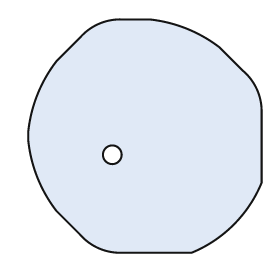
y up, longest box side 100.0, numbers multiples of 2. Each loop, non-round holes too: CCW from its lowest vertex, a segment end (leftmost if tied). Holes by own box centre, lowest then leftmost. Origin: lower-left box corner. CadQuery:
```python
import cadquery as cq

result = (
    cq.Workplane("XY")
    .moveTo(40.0, 0.0)
    .lineTo(70.0, 0.0)
    .threePointArc((88.0, 12.0), (100.0, 30.0))
    .lineTo(100.0, 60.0)
    .threePointArc((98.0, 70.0), (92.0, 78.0))
    .lineTo(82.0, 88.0)
    .threePointArc((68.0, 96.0), (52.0, 100.0))
    .lineTo(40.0, 100.0)
    .threePointArc((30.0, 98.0), (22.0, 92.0))
    .lineTo(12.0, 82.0)
    .threePointArc((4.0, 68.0), (0.0, 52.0))
    .lineTo(0.0, 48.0)
    .threePointArc((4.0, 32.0), (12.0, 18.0))
    .lineTo(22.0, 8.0)
    .threePointArc((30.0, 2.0), (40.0, 0.0))
    .close()
    .moveTo(36.0, 42.0)
    .circle(4.0)
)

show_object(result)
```